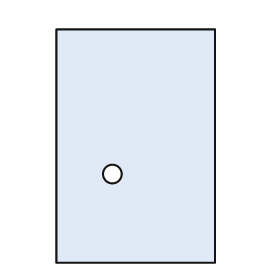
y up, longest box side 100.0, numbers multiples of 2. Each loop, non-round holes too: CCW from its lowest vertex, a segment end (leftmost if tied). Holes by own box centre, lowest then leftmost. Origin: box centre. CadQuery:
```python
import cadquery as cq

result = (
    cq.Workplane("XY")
    .moveTo(-34.0, -50.0)
    .lineTo(34.0, -50.0)
    .lineTo(34.0, 50.0)
    .lineTo(-34.0, 50.0)
    .close()
    .moveTo(-10.0, -12.0)
    .circle(4.0)
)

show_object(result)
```